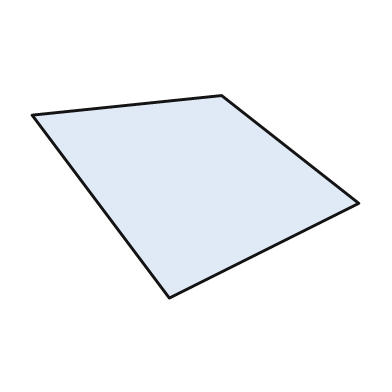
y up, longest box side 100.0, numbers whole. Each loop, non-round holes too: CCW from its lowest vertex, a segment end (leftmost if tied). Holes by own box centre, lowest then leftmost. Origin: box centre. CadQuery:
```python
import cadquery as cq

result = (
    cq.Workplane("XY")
    .moveTo(-8.0, -31.0)
    .lineTo(50.0, -2.0)
    .lineTo(8.0, 31.0)
    .lineTo(-50.0, 25.0)
    .close()
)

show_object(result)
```